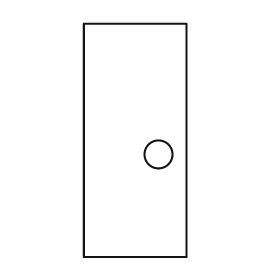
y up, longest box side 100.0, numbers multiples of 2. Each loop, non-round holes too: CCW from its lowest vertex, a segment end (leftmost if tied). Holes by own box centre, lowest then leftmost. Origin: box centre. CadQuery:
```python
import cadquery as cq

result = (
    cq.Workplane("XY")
    .moveTo(-22.0, -50.0)
    .lineTo(22.0, -50.0)
    .lineTo(22.0, 50.0)
    .lineTo(-22.0, 50.0)
    .close()
    .moveTo(10.0, -6.0)
    .circle(6.0)
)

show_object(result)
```